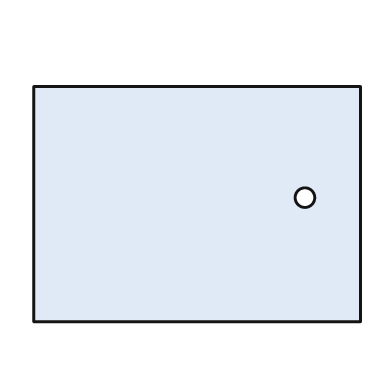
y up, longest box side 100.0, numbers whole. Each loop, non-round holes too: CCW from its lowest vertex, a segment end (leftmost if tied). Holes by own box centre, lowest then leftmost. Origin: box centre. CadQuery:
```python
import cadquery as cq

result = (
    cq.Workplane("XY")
    .moveTo(-50.0, -36.0)
    .lineTo(50.0, -36.0)
    .lineTo(50.0, 36.0)
    .lineTo(-50.0, 36.0)
    .close()
    .moveTo(33.0, 2.0)
    .circle(3.0)
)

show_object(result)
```